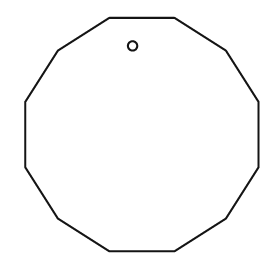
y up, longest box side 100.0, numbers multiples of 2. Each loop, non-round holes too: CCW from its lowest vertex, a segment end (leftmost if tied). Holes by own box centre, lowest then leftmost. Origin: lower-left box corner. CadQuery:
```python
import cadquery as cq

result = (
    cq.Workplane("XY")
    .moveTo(36.0, 0.0)
    .lineTo(64.0, 0.0)
    .lineTo(86.0, 14.0)
    .lineTo(100.0, 36.0)
    .lineTo(100.0, 64.0)
    .lineTo(86.0, 86.0)
    .lineTo(64.0, 100.0)
    .lineTo(36.0, 100.0)
    .lineTo(14.0, 86.0)
    .lineTo(0.0, 64.0)
    .lineTo(0.0, 36.0)
    .lineTo(14.0, 14.0)
    .close()
    .moveTo(46.0, 88.0)
    .circle(2.0)
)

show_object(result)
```